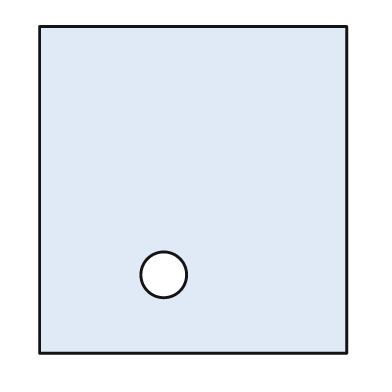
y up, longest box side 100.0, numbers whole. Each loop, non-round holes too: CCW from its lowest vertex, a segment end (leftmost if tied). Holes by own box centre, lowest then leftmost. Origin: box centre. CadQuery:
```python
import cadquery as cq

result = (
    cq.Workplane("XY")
    .moveTo(-47.0, -50.0)
    .lineTo(47.0, -50.0)
    .lineTo(47.0, 50.0)
    .lineTo(-47.0, 50.0)
    .close()
    .moveTo(-9.0, -26.0)
    .circle(7.0)
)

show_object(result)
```